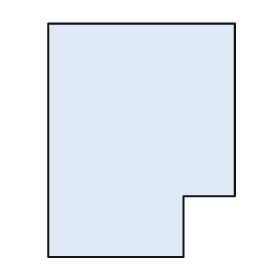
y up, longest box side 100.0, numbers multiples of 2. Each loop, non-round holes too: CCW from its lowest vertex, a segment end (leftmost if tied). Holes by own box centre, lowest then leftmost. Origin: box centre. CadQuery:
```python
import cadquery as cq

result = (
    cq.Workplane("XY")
    .moveTo(-40.0, -50.0)
    .lineTo(18.0, -50.0)
    .lineTo(18.0, -24.0)
    .lineTo(40.0, -24.0)
    .lineTo(40.0, 50.0)
    .lineTo(-40.0, 50.0)
    .close()
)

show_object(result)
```